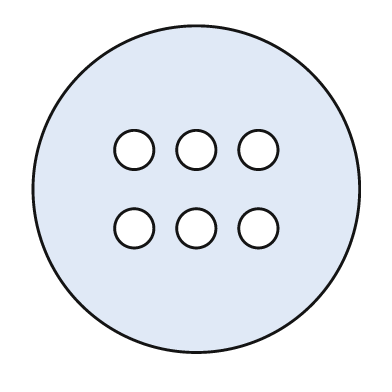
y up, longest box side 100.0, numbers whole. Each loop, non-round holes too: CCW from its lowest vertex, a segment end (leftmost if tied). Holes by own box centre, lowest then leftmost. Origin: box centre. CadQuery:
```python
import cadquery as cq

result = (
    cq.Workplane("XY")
    .moveTo(0.0, 0.0)
    .circle(50.0)
    .moveTo(-19.0, -12.0)
    .circle(6.0)
    .moveTo(0.0, -12.0)
    .circle(6.0)
    .moveTo(19.0, -12.0)
    .circle(6.0)
    .moveTo(-19.0, 12.0)
    .circle(6.0)
    .moveTo(0.0, 12.0)
    .circle(6.0)
    .moveTo(19.0, 12.0)
    .circle(6.0)
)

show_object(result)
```